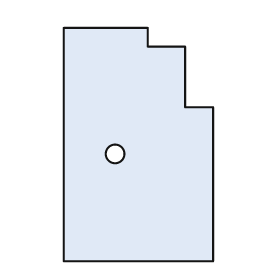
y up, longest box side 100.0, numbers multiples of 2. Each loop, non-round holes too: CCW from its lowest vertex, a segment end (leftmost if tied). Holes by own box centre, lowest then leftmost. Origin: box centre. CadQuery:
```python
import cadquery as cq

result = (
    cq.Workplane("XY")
    .moveTo(-32.0, -50.0)
    .lineTo(32.0, -50.0)
    .lineTo(32.0, 16.0)
    .lineTo(20.0, 16.0)
    .lineTo(20.0, 42.0)
    .lineTo(4.0, 42.0)
    .lineTo(4.0, 50.0)
    .lineTo(-32.0, 50.0)
    .close()
    .moveTo(-10.0, -4.0)
    .circle(4.0)
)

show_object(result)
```